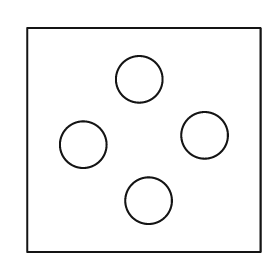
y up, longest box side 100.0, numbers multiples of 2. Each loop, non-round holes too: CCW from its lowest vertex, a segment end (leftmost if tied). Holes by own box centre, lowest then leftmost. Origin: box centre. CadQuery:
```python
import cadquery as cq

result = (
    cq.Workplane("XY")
    .moveTo(-50.0, -48.0)
    .lineTo(50.0, -48.0)
    .lineTo(50.0, 48.0)
    .lineTo(-50.0, 48.0)
    .close()
    .moveTo(2.0, -26.0)
    .circle(10.0)
    .moveTo(-26.0, -2.0)
    .circle(10.0)
    .moveTo(26.0, 2.0)
    .circle(10.0)
    .moveTo(-2.0, 26.0)
    .circle(10.0)
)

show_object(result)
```